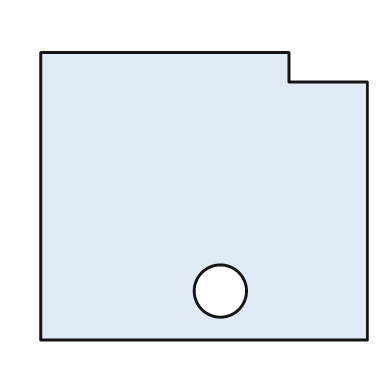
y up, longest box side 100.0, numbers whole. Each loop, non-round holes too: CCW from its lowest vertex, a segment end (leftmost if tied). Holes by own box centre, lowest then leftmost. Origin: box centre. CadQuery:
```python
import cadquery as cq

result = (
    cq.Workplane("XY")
    .moveTo(-50.0, -44.0)
    .lineTo(50.0, -44.0)
    .lineTo(50.0, 35.0)
    .lineTo(26.0, 35.0)
    .lineTo(26.0, 44.0)
    .lineTo(-50.0, 44.0)
    .close()
    .moveTo(5.0, -29.0)
    .circle(8.0)
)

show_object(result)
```